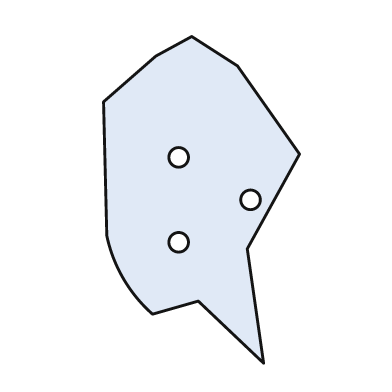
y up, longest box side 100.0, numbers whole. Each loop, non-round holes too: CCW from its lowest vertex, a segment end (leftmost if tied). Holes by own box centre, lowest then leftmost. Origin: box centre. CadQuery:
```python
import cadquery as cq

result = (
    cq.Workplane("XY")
    .moveTo(19.0, -50.0)
    .lineTo(14.0, -15.0)
    .lineTo(30.0, 14.0)
    .lineTo(11.0, 41.0)
    .lineTo(-3.0, 50.0)
    .lineTo(-14.0, 44.0)
    .lineTo(-30.0, 30.0)
    .lineTo(-29.0, -11.0)
    .threePointArc((-24.0, -24.0), (-15.0, -35.0))
    .lineTo(-1.0, -31.0)
    .close()
    .moveTo(-7.0, -13.0)
    .circle(3.0)
    .moveTo(15.0, 0.0)
    .circle(3.0)
    .moveTo(-7.0, 13.0)
    .circle(3.0)
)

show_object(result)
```